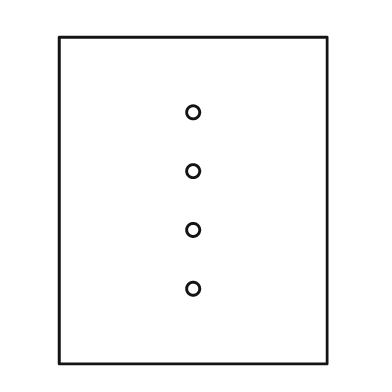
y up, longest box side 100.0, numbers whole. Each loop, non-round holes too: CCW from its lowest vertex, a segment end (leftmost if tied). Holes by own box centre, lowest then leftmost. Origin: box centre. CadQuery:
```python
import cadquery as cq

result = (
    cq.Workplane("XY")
    .moveTo(-41.0, -50.0)
    .lineTo(41.0, -50.0)
    .lineTo(41.0, 50.0)
    .lineTo(-41.0, 50.0)
    .close()
    .moveTo(0.0, -27.0)
    .circle(2.0)
    .moveTo(0.0, -9.0)
    .circle(2.0)
    .moveTo(0.0, 9.0)
    .circle(2.0)
    .moveTo(0.0, 27.0)
    .circle(2.0)
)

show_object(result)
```